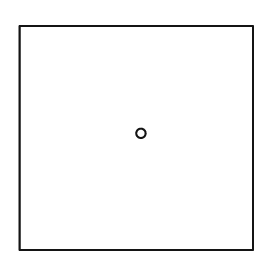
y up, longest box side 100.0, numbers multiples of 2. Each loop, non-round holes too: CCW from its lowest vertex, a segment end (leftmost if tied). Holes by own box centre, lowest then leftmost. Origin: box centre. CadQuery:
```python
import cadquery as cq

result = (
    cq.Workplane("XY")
    .moveTo(-50.0, -48.0)
    .lineTo(50.0, -48.0)
    .lineTo(50.0, 48.0)
    .lineTo(-50.0, 48.0)
    .close()
    .moveTo(2.0, 2.0)
    .circle(2.0)
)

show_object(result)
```